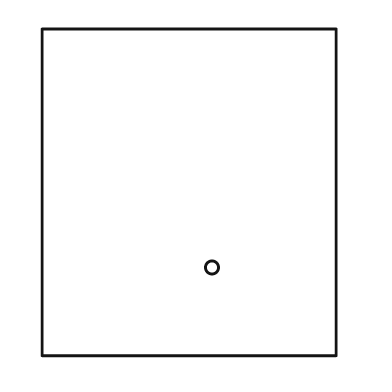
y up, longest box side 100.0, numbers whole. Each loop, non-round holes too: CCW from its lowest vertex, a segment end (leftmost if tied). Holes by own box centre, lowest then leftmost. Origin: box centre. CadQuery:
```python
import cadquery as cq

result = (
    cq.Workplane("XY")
    .moveTo(-45.0, -50.0)
    .lineTo(45.0, -50.0)
    .lineTo(45.0, 50.0)
    .lineTo(-45.0, 50.0)
    .close()
    .moveTo(7.0, -23.0)
    .circle(2.0)
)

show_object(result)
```